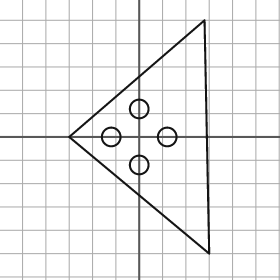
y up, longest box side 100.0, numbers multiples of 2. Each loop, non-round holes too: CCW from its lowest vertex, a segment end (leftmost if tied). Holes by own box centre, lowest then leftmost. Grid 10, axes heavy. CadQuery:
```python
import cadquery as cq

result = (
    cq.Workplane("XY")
    .moveTo(30.0, -50.0)
    .lineTo(28.0, 50.0)
    .lineTo(-30.0, 0.0)
    .close()
    .moveTo(0.0, -12.0)
    .circle(4.0)
    .moveTo(-12.0, 0.0)
    .circle(4.0)
    .moveTo(12.0, 0.0)
    .circle(4.0)
    .moveTo(0.0, 12.0)
    .circle(4.0)
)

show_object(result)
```